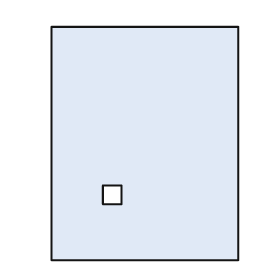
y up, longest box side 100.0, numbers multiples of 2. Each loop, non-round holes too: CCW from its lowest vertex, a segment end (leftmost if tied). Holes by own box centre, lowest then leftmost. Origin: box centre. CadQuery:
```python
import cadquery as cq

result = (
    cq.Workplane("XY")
    .moveTo(-40.0, -50.0)
    .lineTo(40.0, -50.0)
    .lineTo(40.0, 50.0)
    .lineTo(-40.0, 50.0)
    .close()
    .moveTo(-18.0, -26.0)
    .lineTo(-10.0, -26.0)
    .lineTo(-10.0, -18.0)
    .lineTo(-18.0, -18.0)
    .close()
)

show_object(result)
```